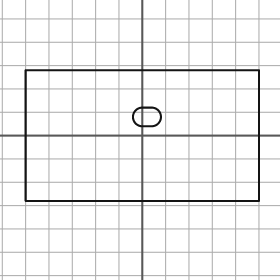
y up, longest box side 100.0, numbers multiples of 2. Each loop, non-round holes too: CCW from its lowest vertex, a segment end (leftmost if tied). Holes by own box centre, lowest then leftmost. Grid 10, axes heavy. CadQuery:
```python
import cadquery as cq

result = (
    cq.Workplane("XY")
    .moveTo(-50.0, -28.0)
    .lineTo(50.0, -28.0)
    .lineTo(50.0, 28.0)
    .lineTo(-50.0, 28.0)
    .close()
    .moveTo(0.0, 4.0)
    .lineTo(4.0, 4.0)
    .threePointArc((8.0, 8.0), (4.0, 12.0))
    .lineTo(0.0, 12.0)
    .threePointArc((-4.0, 8.0), (0.0, 4.0))
    .close()
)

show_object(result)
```